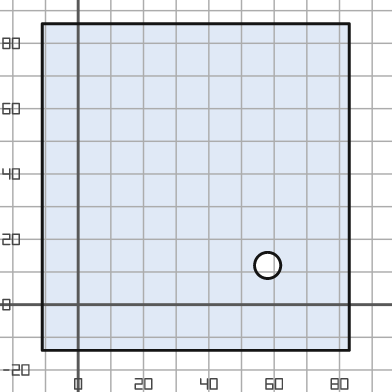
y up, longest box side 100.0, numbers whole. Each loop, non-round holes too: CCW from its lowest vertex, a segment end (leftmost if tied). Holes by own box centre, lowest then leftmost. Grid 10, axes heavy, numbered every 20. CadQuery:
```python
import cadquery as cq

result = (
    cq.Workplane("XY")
    .moveTo(-11.0, -14.0)
    .lineTo(83.0, -14.0)
    .lineTo(83.0, 86.0)
    .lineTo(-11.0, 86.0)
    .close()
    .moveTo(58.0, 12.0)
    .circle(4.0)
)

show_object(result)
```